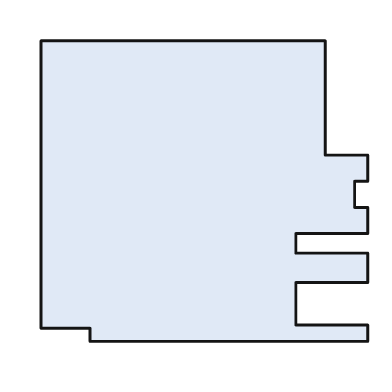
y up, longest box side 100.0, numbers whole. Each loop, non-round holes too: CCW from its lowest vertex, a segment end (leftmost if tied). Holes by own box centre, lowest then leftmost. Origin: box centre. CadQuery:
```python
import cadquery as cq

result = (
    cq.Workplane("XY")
    .moveTo(-35.0, -46.0)
    .lineTo(50.0, -46.0)
    .lineTo(50.0, -41.0)
    .lineTo(28.0, -41.0)
    .lineTo(28.0, -28.0)
    .lineTo(50.0, -28.0)
    .lineTo(50.0, -19.0)
    .lineTo(28.0, -19.0)
    .lineTo(28.0, -13.0)
    .lineTo(50.0, -13.0)
    .lineTo(50.0, -5.0)
    .lineTo(46.0, -5.0)
    .lineTo(46.0, 3.0)
    .lineTo(50.0, 3.0)
    .lineTo(50.0, 11.0)
    .lineTo(37.0, 11.0)
    .lineTo(37.0, 46.0)
    .lineTo(-50.0, 46.0)
    .lineTo(-50.0, -42.0)
    .lineTo(-35.0, -42.0)
    .close()
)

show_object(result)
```